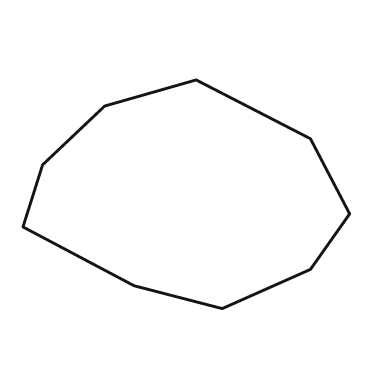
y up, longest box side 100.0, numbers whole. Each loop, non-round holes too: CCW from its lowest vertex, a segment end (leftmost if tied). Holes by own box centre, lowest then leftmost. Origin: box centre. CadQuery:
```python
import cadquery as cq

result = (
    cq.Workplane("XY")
    .moveTo(11.0, -35.0)
    .lineTo(38.0, -23.0)
    .lineTo(50.0, -6.0)
    .lineTo(38.0, 17.0)
    .lineTo(3.0, 35.0)
    .lineTo(-25.0, 27.0)
    .lineTo(-44.0, 9.0)
    .lineTo(-50.0, -10.0)
    .lineTo(-16.0, -28.0)
    .close()
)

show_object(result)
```